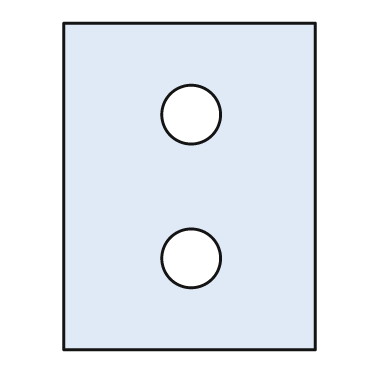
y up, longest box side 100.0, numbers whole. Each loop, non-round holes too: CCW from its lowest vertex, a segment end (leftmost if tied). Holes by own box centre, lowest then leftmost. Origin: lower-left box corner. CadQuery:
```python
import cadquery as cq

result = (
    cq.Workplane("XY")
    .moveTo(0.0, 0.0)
    .lineTo(77.0, 0.0)
    .lineTo(77.0, 100.0)
    .lineTo(0.0, 100.0)
    .close()
    .moveTo(39.0, 28.0)
    .circle(9.0)
    .moveTo(39.0, 72.0)
    .circle(9.0)
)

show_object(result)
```